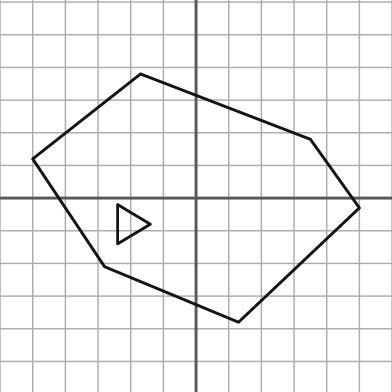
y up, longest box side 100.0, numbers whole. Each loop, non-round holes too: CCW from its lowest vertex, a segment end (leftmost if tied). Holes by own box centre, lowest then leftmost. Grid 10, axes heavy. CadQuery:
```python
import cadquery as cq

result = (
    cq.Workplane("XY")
    .moveTo(13.0, -38.0)
    .lineTo(50.0, -3.0)
    .lineTo(35.0, 18.0)
    .lineTo(-17.0, 38.0)
    .lineTo(-50.0, 12.0)
    .lineTo(-28.0, -21.0)
    .close()
    .moveTo(-24.0, -14.0)
    .lineTo(-14.0, -8.0)
    .lineTo(-24.0, -2.0)
    .close()
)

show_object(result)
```